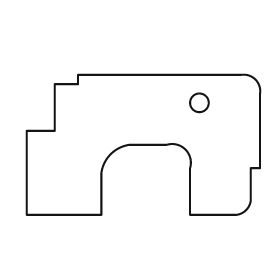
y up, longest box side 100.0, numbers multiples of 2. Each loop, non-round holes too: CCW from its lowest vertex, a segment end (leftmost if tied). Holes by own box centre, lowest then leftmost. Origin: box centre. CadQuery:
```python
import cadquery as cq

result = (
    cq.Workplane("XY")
    .moveTo(-50.0, -30.0)
    .lineTo(-18.0, -30.0)
    .lineTo(-18.0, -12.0)
    .threePointArc((-14.0, -4.0), (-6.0, 0.0))
    .lineTo(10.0, 0.0)
    .threePointArc((18.0, -2.0), (20.0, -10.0))
    .lineTo(20.0, -30.0)
    .lineTo(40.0, -30.0)
    .threePointArc((44.0, -28.0), (46.0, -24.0))
    .lineTo(46.0, -10.0)
    .lineTo(50.0, -10.0)
    .lineTo(50.0, 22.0)
    .threePointArc((48.0, 28.0), (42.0, 30.0))
    .lineTo(-28.0, 30.0)
    .lineTo(-28.0, 26.0)
    .lineTo(-38.0, 26.0)
    .lineTo(-38.0, 6.0)
    .lineTo(-50.0, 6.0)
    .close()
    .moveTo(24.0, 18.0)
    .circle(4.0)
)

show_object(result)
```